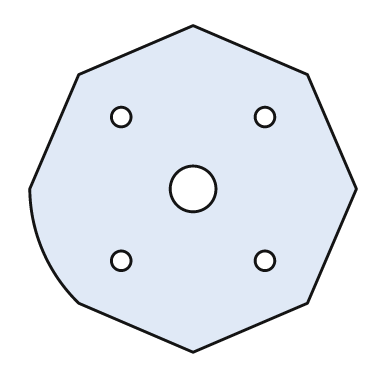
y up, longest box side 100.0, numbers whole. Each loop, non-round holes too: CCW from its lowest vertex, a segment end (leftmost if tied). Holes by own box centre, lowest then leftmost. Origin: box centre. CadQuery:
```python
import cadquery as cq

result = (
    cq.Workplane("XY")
    .moveTo(0.0, -50.0)
    .lineTo(35.0, -35.0)
    .lineTo(50.0, 0.0)
    .lineTo(35.0, 35.0)
    .lineTo(0.0, 50.0)
    .lineTo(-35.0, 35.0)
    .lineTo(-50.0, 0.0)
    .threePointArc((-46.0, -19.0), (-35.0, -35.0))
    .close()
    .moveTo(-22.0, -22.0)
    .circle(3.0)
    .moveTo(22.0, -22.0)
    .circle(3.0)
    .moveTo(0.0, 0.0)
    .circle(7.0)
    .moveTo(-22.0, 22.0)
    .circle(3.0)
    .moveTo(22.0, 22.0)
    .circle(3.0)
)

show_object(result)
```